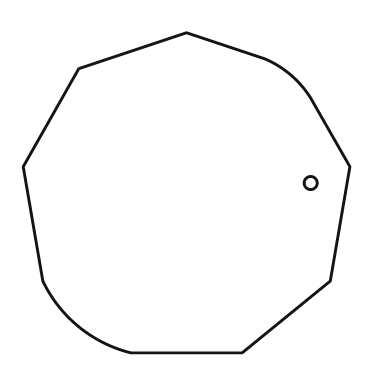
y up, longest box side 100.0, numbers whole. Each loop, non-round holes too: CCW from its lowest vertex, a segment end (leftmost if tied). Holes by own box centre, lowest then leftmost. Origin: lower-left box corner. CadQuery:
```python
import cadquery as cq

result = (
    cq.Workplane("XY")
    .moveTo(33.0, 0.0)
    .lineTo(67.0, 0.0)
    .lineTo(94.0, 22.0)
    .lineTo(100.0, 57.0)
    .lineTo(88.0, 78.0)
    .threePointArc((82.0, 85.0), (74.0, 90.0))
    .lineTo(50.0, 98.0)
    .lineTo(17.0, 87.0)
    .lineTo(0.0, 57.0)
    .lineTo(6.0, 22.0)
    .threePointArc((17.0, 8.0), (33.0, 0.0))
    .close()
    .moveTo(88.0, 52.0)
    .circle(2.0)
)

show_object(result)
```